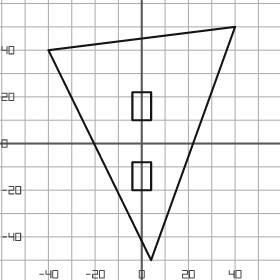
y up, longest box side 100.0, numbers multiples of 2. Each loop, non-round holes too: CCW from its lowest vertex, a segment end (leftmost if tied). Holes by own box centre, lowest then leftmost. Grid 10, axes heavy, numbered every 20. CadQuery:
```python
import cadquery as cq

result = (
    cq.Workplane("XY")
    .moveTo(4.0, -50.0)
    .lineTo(40.0, 50.0)
    .lineTo(-40.0, 40.0)
    .close()
    .moveTo(-4.0, -20.0)
    .lineTo(4.0, -20.0)
    .lineTo(4.0, -8.0)
    .lineTo(-4.0, -8.0)
    .close()
    .moveTo(-4.0, 10.0)
    .lineTo(4.0, 10.0)
    .lineTo(4.0, 22.0)
    .lineTo(-4.0, 22.0)
    .close()
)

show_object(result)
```